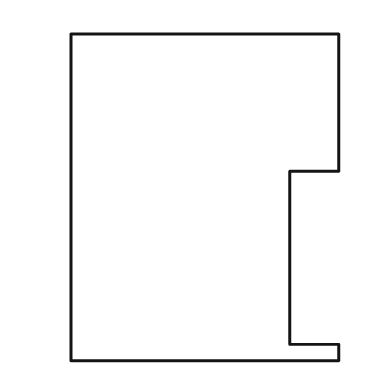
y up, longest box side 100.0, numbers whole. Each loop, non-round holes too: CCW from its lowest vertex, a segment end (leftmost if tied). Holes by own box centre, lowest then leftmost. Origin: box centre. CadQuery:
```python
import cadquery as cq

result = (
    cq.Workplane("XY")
    .moveTo(-41.0, -50.0)
    .lineTo(41.0, -50.0)
    .lineTo(41.0, -45.0)
    .lineTo(26.0, -45.0)
    .lineTo(26.0, 8.0)
    .lineTo(41.0, 8.0)
    .lineTo(41.0, 50.0)
    .lineTo(-41.0, 50.0)
    .close()
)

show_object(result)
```